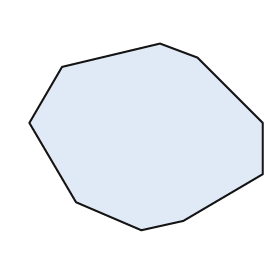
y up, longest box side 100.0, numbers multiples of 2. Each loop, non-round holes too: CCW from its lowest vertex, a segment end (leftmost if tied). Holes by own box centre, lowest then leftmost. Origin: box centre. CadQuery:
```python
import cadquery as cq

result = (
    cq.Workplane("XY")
    .moveTo(-2.0, -40.0)
    .lineTo(16.0, -36.0)
    .lineTo(50.0, -16.0)
    .lineTo(50.0, 6.0)
    .lineTo(22.0, 34.0)
    .lineTo(6.0, 40.0)
    .lineTo(-36.0, 30.0)
    .lineTo(-50.0, 6.0)
    .lineTo(-30.0, -28.0)
    .close()
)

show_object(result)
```